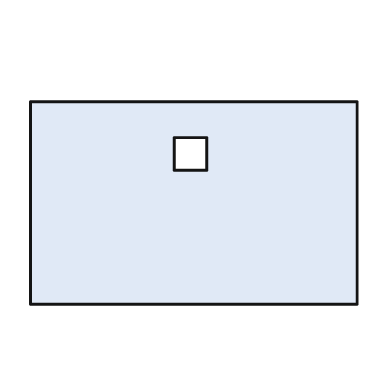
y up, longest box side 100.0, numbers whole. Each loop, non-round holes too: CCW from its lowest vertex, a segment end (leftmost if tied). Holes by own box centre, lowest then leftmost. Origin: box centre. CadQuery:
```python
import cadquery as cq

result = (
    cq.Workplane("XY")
    .moveTo(-50.0, -31.0)
    .lineTo(50.0, -31.0)
    .lineTo(50.0, 31.0)
    .lineTo(-50.0, 31.0)
    .close()
    .moveTo(-6.0, 10.0)
    .lineTo(4.0, 10.0)
    .lineTo(4.0, 20.0)
    .lineTo(-6.0, 20.0)
    .close()
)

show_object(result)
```